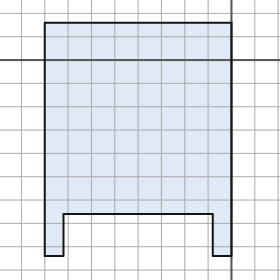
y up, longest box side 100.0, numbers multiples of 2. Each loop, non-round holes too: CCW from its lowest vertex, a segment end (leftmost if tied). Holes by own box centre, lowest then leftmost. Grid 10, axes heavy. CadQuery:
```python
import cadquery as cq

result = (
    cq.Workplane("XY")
    .moveTo(-80.0, -84.0)
    .lineTo(-72.0, -84.0)
    .lineTo(-72.0, -66.0)
    .lineTo(-8.0, -66.0)
    .lineTo(-8.0, -84.0)
    .lineTo(0.0, -84.0)
    .lineTo(0.0, 16.0)
    .lineTo(-80.0, 16.0)
    .close()
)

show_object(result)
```